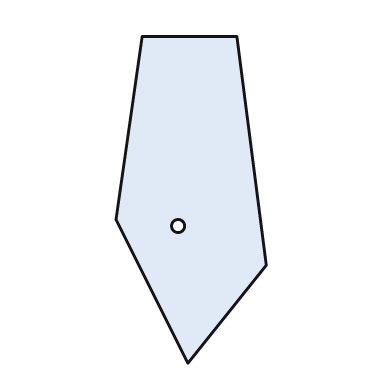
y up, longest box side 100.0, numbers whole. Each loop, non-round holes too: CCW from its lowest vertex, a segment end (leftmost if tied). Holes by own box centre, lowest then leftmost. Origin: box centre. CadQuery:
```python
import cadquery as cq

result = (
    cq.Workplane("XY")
    .moveTo(-1.0, -50.0)
    .lineTo(23.0, -20.0)
    .lineTo(14.0, 50.0)
    .lineTo(-15.0, 50.0)
    .lineTo(-23.0, -6.0)
    .close()
    .moveTo(-4.0, -8.0)
    .circle(2.0)
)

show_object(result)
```